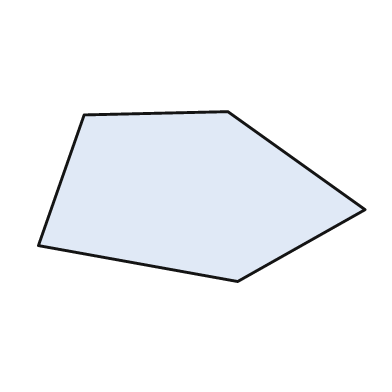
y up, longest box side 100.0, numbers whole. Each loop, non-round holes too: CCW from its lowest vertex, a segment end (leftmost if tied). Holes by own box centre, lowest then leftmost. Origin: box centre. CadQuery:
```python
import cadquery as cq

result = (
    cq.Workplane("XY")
    .moveTo(11.0, -26.0)
    .lineTo(50.0, -4.0)
    .lineTo(8.0, 26.0)
    .lineTo(-36.0, 25.0)
    .lineTo(-50.0, -15.0)
    .close()
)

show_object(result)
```